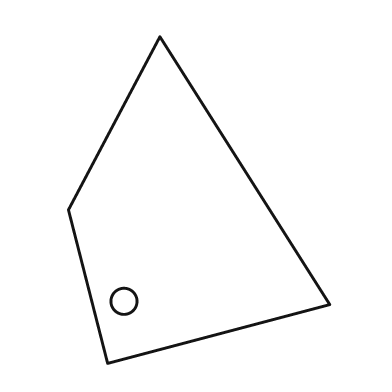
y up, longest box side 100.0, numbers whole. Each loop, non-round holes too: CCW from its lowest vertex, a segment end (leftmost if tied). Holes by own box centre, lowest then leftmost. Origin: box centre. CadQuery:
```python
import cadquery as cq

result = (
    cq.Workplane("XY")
    .moveTo(-28.0, -50.0)
    .lineTo(40.0, -32.0)
    .lineTo(-12.0, 50.0)
    .lineTo(-40.0, -3.0)
    .close()
    .moveTo(-23.0, -31.0)
    .circle(4.0)
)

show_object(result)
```